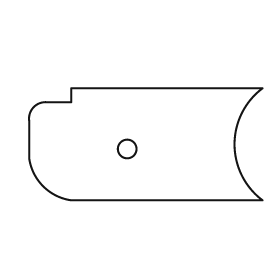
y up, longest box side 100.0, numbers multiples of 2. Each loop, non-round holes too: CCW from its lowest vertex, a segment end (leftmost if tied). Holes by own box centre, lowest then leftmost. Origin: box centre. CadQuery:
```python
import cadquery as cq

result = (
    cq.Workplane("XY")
    .moveTo(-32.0, -24.0)
    .lineTo(50.0, -24.0)
    .threePointArc((38.0, 0.0), (50.0, 24.0))
    .lineTo(-32.0, 24.0)
    .lineTo(-32.0, 18.0)
    .lineTo(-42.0, 18.0)
    .threePointArc((-48.0, 16.0), (-50.0, 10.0))
    .lineTo(-50.0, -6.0)
    .threePointArc((-44.0, -18.0), (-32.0, -24.0))
    .close()
    .moveTo(-8.0, -2.0)
    .circle(4.0)
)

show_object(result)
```